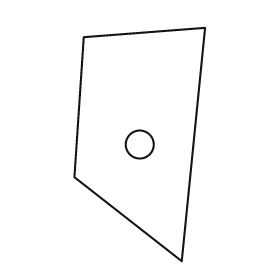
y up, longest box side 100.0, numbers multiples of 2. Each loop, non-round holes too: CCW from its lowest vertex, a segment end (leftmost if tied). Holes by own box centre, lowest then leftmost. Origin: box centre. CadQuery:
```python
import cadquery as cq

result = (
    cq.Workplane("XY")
    .moveTo(18.0, -50.0)
    .lineTo(28.0, 50.0)
    .lineTo(-24.0, 46.0)
    .lineTo(-28.0, -14.0)
    .close()
    .moveTo(0.0, 0.0)
    .circle(6.0)
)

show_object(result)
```